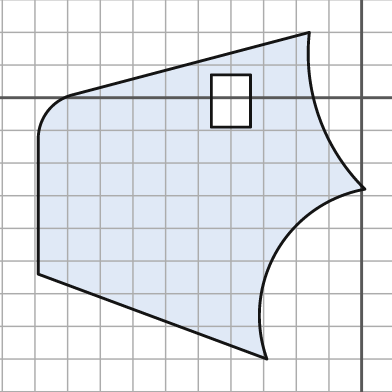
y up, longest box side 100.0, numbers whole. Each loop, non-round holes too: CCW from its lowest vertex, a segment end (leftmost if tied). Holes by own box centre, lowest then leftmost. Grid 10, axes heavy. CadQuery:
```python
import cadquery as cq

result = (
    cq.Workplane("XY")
    .moveTo(-29.0, -80.0)
    .threePointArc((-26.0, -47.0), (1.0, -28.0))
    .threePointArc((-13.0, -6.0), (-16.0, 20.0))
    .lineTo(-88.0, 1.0)
    .threePointArc((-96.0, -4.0), (-99.0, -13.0))
    .lineTo(-99.0, -54.0)
    .close()
    .moveTo(-46.0, -9.0)
    .lineTo(-34.0, -9.0)
    .lineTo(-34.0, 7.0)
    .lineTo(-46.0, 7.0)
    .close()
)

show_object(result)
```